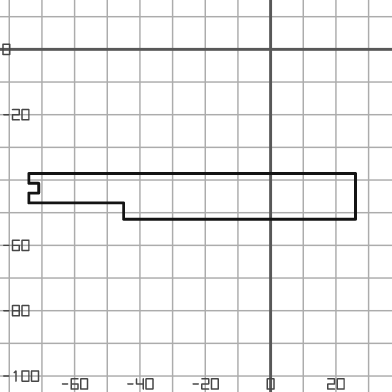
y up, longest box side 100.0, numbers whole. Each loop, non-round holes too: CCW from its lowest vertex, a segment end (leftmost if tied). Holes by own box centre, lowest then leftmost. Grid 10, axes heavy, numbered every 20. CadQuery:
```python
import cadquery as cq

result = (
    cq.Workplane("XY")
    .moveTo(-45.0, -52.0)
    .lineTo(26.0, -52.0)
    .lineTo(26.0, -38.0)
    .lineTo(-74.0, -38.0)
    .lineTo(-74.0, -41.0)
    .lineTo(-71.0, -41.0)
    .lineTo(-71.0, -44.0)
    .lineTo(-74.0, -44.0)
    .lineTo(-74.0, -47.0)
    .lineTo(-45.0, -47.0)
    .close()
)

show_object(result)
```